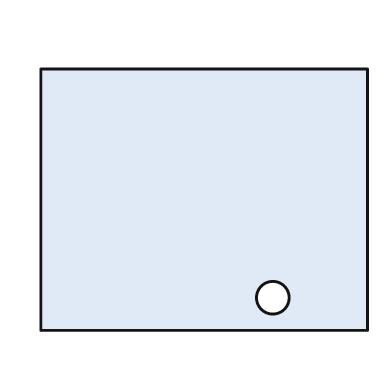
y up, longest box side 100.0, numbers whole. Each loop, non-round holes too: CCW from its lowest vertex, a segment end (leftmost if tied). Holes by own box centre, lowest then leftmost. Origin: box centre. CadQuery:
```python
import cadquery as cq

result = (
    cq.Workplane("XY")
    .moveTo(-50.0, -40.0)
    .lineTo(50.0, -40.0)
    .lineTo(50.0, 40.0)
    .lineTo(-50.0, 40.0)
    .close()
    .moveTo(21.0, -30.0)
    .circle(5.0)
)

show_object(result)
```